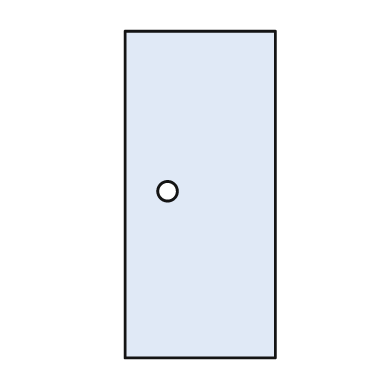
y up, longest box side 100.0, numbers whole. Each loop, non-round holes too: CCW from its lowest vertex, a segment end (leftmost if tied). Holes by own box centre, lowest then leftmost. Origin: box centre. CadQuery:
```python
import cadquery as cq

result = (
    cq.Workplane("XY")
    .moveTo(-23.0, -50.0)
    .lineTo(23.0, -50.0)
    .lineTo(23.0, 50.0)
    .lineTo(-23.0, 50.0)
    .close()
    .moveTo(-10.0, 1.0)
    .circle(3.0)
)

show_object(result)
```